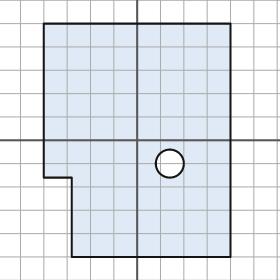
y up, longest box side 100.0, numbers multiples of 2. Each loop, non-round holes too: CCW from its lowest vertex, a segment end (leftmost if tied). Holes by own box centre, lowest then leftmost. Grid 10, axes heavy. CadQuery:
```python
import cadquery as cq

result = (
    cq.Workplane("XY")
    .moveTo(-28.0, -50.0)
    .lineTo(40.0, -50.0)
    .lineTo(40.0, 50.0)
    .lineTo(-40.0, 50.0)
    .lineTo(-40.0, -16.0)
    .lineTo(-28.0, -16.0)
    .close()
    .moveTo(14.0, -10.0)
    .circle(6.0)
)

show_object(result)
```